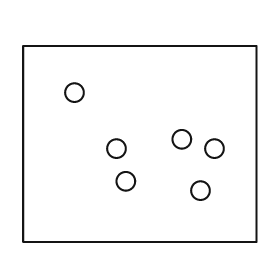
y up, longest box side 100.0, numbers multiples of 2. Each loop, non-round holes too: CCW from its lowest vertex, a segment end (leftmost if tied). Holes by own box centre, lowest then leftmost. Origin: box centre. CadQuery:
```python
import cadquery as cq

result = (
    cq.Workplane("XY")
    .moveTo(-50.0, -42.0)
    .lineTo(50.0, -42.0)
    .lineTo(50.0, 42.0)
    .lineTo(-50.0, 42.0)
    .close()
    .moveTo(26.0, -20.0)
    .circle(4.0)
    .moveTo(-6.0, -16.0)
    .circle(4.0)
    .moveTo(-10.0, -2.0)
    .circle(4.0)
    .moveTo(32.0, -2.0)
    .circle(4.0)
    .moveTo(18.0, 2.0)
    .circle(4.0)
    .moveTo(-28.0, 22.0)
    .circle(4.0)
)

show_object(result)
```